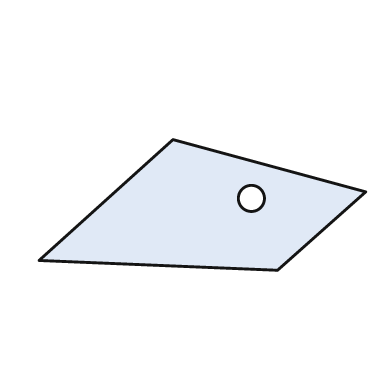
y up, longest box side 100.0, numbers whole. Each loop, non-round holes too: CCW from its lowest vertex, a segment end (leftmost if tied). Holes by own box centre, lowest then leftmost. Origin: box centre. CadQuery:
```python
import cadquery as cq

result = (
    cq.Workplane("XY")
    .moveTo(23.0, -20.0)
    .lineTo(50.0, 4.0)
    .lineTo(-9.0, 20.0)
    .lineTo(-50.0, -17.0)
    .close()
    .moveTo(15.0, 2.0)
    .circle(4.0)
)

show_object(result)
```